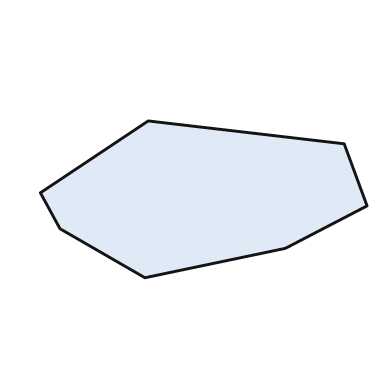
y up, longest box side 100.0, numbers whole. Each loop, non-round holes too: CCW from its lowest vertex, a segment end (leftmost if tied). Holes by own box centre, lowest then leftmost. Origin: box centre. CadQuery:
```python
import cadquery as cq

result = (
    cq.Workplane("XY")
    .moveTo(-18.0, -24.0)
    .lineTo(25.0, -15.0)
    .lineTo(50.0, -2.0)
    .lineTo(43.0, 17.0)
    .lineTo(-17.0, 24.0)
    .lineTo(-50.0, 2.0)
    .lineTo(-44.0, -9.0)
    .close()
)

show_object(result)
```